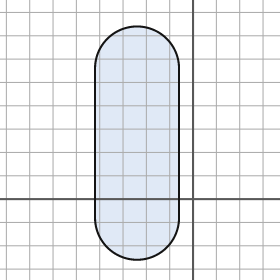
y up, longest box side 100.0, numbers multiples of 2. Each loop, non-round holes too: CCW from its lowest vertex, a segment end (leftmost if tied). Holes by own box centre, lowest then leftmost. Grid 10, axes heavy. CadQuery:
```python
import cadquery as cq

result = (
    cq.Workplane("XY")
    .moveTo(-42.0, -8.0)
    .threePointArc((-24.0, -26.0), (-6.0, -8.0))
    .lineTo(-6.0, 56.0)
    .threePointArc((-24.0, 74.0), (-42.0, 56.0))
    .close()
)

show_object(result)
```